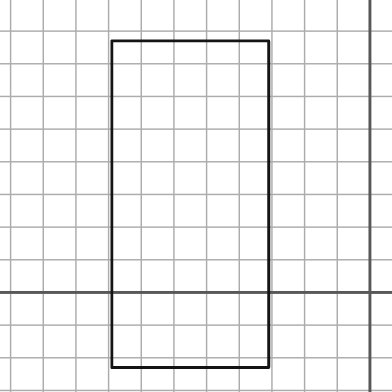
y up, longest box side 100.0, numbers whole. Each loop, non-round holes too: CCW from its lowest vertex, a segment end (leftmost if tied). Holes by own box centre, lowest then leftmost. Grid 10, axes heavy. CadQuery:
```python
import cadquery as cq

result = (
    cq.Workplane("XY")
    .moveTo(-79.0, -23.0)
    .lineTo(-31.0, -23.0)
    .lineTo(-31.0, 77.0)
    .lineTo(-79.0, 77.0)
    .close()
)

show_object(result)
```